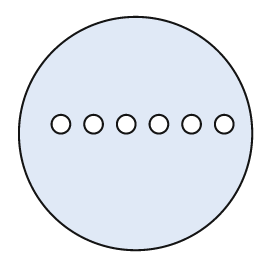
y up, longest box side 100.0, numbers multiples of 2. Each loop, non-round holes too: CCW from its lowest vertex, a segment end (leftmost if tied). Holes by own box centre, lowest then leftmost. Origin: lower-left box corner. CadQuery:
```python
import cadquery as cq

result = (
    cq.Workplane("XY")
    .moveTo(50.0, 50.0)
    .circle(50.0)
    .moveTo(18.0, 54.0)
    .circle(4.0)
    .moveTo(32.0, 54.0)
    .circle(4.0)
    .moveTo(46.0, 54.0)
    .circle(4.0)
    .moveTo(60.0, 54.0)
    .circle(4.0)
    .moveTo(74.0, 54.0)
    .circle(4.0)
    .moveTo(88.0, 54.0)
    .circle(4.0)
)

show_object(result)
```